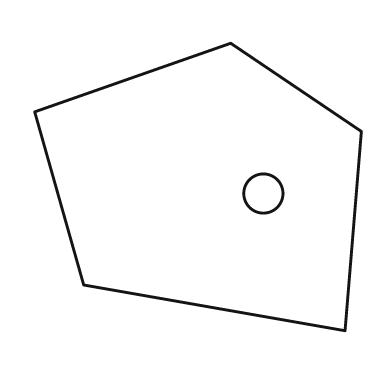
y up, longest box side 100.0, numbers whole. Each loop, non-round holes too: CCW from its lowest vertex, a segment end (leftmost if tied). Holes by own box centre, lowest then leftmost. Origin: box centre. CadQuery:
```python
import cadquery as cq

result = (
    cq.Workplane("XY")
    .moveTo(45.0, -44.0)
    .lineTo(50.0, 17.0)
    .lineTo(10.0, 44.0)
    .lineTo(-50.0, 23.0)
    .lineTo(-35.0, -30.0)
    .close()
    .moveTo(20.0, -2.0)
    .circle(6.0)
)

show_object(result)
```